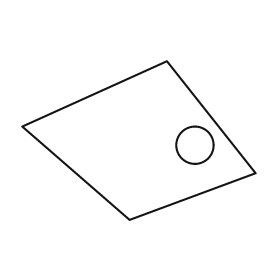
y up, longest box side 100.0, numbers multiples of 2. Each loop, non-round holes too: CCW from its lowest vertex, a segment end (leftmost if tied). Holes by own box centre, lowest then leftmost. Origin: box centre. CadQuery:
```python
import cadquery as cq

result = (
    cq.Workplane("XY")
    .moveTo(-4.0, -34.0)
    .lineTo(50.0, -14.0)
    .lineTo(12.0, 34.0)
    .lineTo(-50.0, 6.0)
    .close()
    .moveTo(24.0, -2.0)
    .circle(8.0)
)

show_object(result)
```